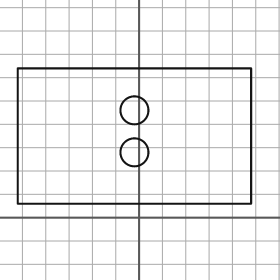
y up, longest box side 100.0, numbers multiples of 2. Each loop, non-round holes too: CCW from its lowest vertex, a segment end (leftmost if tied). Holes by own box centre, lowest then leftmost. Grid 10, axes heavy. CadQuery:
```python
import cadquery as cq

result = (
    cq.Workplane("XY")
    .moveTo(-52.0, 6.0)
    .lineTo(48.0, 6.0)
    .lineTo(48.0, 64.0)
    .lineTo(-52.0, 64.0)
    .close()
    .moveTo(-2.0, 28.0)
    .circle(6.0)
    .moveTo(-2.0, 46.0)
    .circle(6.0)
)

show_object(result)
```